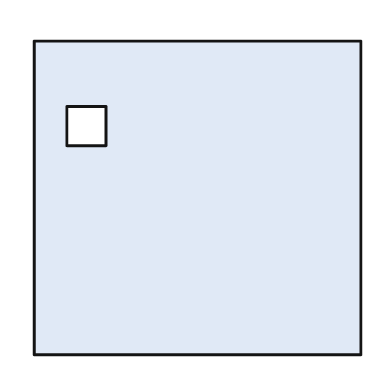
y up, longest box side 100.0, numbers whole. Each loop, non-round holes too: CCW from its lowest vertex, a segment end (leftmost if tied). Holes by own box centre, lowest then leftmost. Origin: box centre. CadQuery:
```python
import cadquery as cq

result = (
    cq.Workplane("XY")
    .moveTo(-50.0, -48.0)
    .lineTo(50.0, -48.0)
    .lineTo(50.0, 48.0)
    .lineTo(-50.0, 48.0)
    .close()
    .moveTo(-40.0, 16.0)
    .lineTo(-28.0, 16.0)
    .lineTo(-28.0, 28.0)
    .lineTo(-40.0, 28.0)
    .close()
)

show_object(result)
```